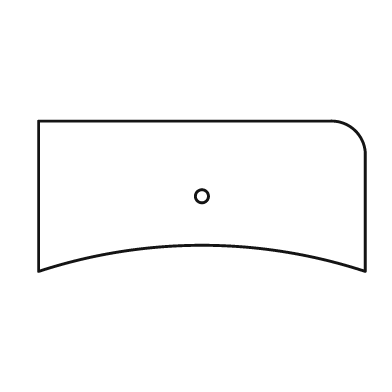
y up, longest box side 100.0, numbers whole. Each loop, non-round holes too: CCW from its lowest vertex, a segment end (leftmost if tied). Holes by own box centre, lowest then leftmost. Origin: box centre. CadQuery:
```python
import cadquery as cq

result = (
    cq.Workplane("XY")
    .moveTo(-50.0, -23.0)
    .threePointArc((0.0, -15.0), (50.0, -23.0))
    .lineTo(50.0, 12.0)
    .threePointArc((47.0, 20.0), (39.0, 23.0))
    .lineTo(-50.0, 23.0)
    .close()
    .moveTo(0.0, 0.0)
    .circle(2.0)
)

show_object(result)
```